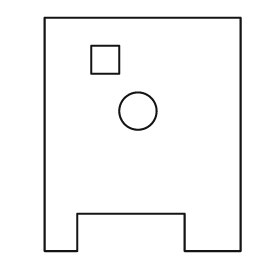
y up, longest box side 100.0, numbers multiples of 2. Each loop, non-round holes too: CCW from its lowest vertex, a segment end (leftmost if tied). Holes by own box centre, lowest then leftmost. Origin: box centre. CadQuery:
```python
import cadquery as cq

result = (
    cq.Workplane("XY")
    .moveTo(-42.0, -50.0)
    .lineTo(-28.0, -50.0)
    .lineTo(-28.0, -34.0)
    .lineTo(18.0, -34.0)
    .lineTo(18.0, -50.0)
    .lineTo(42.0, -50.0)
    .lineTo(42.0, 50.0)
    .lineTo(-42.0, 50.0)
    .close()
    .moveTo(-2.0, 10.0)
    .circle(8.0)
    .moveTo(-22.0, 26.0)
    .lineTo(-10.0, 26.0)
    .lineTo(-10.0, 38.0)
    .lineTo(-22.0, 38.0)
    .close()
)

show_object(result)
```